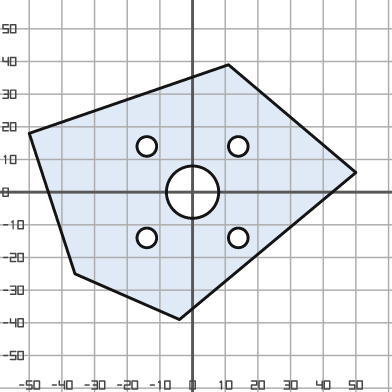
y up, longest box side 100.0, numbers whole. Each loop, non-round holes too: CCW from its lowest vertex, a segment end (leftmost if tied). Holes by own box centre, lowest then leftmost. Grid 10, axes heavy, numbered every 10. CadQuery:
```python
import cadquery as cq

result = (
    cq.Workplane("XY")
    .moveTo(-4.0, -39.0)
    .lineTo(50.0, 6.0)
    .lineTo(11.0, 39.0)
    .lineTo(-50.0, 18.0)
    .lineTo(-36.0, -25.0)
    .close()
    .moveTo(-14.0, -14.0)
    .circle(3.0)
    .moveTo(14.0, -14.0)
    .circle(3.0)
    .moveTo(0.0, 0.0)
    .circle(8.0)
    .moveTo(-14.0, 14.0)
    .circle(3.0)
    .moveTo(14.0, 14.0)
    .circle(3.0)
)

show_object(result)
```